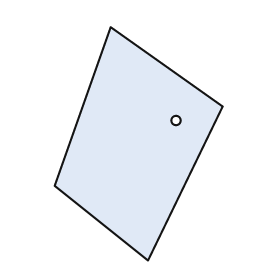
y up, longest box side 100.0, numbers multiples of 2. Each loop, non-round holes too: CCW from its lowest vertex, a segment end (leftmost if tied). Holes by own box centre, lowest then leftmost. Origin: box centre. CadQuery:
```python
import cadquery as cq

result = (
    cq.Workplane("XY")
    .moveTo(4.0, -50.0)
    .lineTo(36.0, 16.0)
    .lineTo(-12.0, 50.0)
    .lineTo(-36.0, -18.0)
    .close()
    .moveTo(16.0, 10.0)
    .circle(2.0)
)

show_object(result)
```